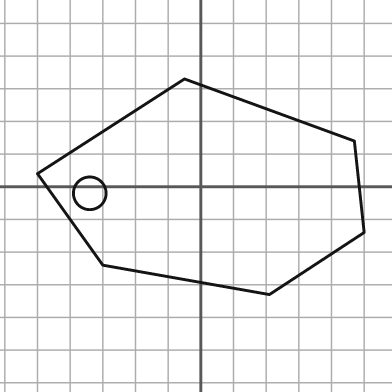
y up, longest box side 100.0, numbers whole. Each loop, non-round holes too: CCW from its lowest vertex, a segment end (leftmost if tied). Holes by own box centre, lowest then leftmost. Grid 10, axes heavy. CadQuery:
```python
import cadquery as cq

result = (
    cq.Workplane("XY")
    .moveTo(21.0, -33.0)
    .lineTo(50.0, -14.0)
    .lineTo(47.0, 14.0)
    .lineTo(-5.0, 33.0)
    .lineTo(-50.0, 4.0)
    .lineTo(-30.0, -24.0)
    .close()
    .moveTo(-34.0, -2.0)
    .circle(5.0)
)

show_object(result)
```